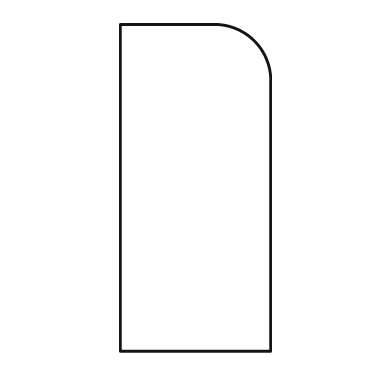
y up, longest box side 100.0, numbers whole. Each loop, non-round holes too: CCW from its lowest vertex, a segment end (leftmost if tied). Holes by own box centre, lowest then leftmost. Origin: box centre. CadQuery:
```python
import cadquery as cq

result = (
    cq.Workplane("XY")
    .moveTo(-23.0, -50.0)
    .lineTo(23.0, -50.0)
    .lineTo(23.0, 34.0)
    .threePointArc((18.0, 45.0), (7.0, 50.0))
    .lineTo(-23.0, 50.0)
    .close()
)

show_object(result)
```